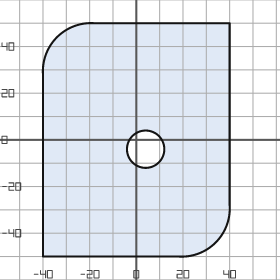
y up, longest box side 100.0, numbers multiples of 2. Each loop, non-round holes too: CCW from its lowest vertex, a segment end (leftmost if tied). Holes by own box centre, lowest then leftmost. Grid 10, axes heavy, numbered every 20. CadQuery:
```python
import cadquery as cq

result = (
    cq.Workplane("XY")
    .moveTo(-40.0, -50.0)
    .lineTo(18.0, -50.0)
    .threePointArc((34.0, -44.0), (40.0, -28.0))
    .lineTo(40.0, 50.0)
    .lineTo(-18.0, 50.0)
    .threePointArc((-34.0, 44.0), (-40.0, 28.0))
    .close()
    .moveTo(4.0, -4.0)
    .circle(8.0)
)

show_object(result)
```